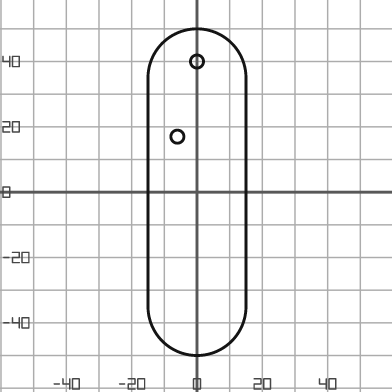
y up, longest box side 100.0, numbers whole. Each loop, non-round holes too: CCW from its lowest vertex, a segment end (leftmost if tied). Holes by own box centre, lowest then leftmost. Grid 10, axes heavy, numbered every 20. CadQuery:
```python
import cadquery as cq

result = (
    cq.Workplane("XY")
    .moveTo(-15.0, -35.0)
    .threePointArc((0.0, -50.0), (15.0, -35.0))
    .lineTo(15.0, 35.0)
    .threePointArc((0.0, 50.0), (-15.0, 35.0))
    .close()
    .moveTo(-6.0, 17.0)
    .circle(2.0)
    .moveTo(0.0, 40.0)
    .circle(2.0)
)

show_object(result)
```